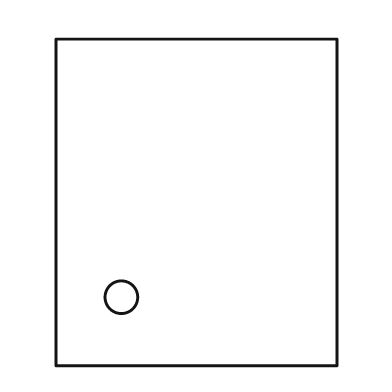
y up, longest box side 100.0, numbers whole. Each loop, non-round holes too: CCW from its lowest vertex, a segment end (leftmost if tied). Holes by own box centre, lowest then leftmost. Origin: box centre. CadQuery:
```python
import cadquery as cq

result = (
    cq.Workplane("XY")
    .moveTo(-43.0, -50.0)
    .lineTo(43.0, -50.0)
    .lineTo(43.0, 50.0)
    .lineTo(-43.0, 50.0)
    .close()
    .moveTo(-23.0, -29.0)
    .circle(5.0)
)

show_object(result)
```